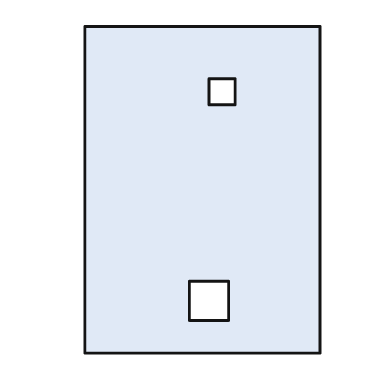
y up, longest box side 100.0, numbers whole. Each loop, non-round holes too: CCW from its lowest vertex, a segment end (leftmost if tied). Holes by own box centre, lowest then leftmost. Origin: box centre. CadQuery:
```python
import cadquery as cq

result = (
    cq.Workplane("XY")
    .moveTo(-36.0, -50.0)
    .lineTo(36.0, -50.0)
    .lineTo(36.0, 50.0)
    .lineTo(-36.0, 50.0)
    .close()
    .moveTo(-4.0, -40.0)
    .lineTo(8.0, -40.0)
    .lineTo(8.0, -28.0)
    .lineTo(-4.0, -28.0)
    .close()
    .moveTo(2.0, 26.0)
    .lineTo(10.0, 26.0)
    .lineTo(10.0, 34.0)
    .lineTo(2.0, 34.0)
    .close()
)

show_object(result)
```